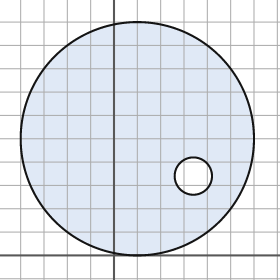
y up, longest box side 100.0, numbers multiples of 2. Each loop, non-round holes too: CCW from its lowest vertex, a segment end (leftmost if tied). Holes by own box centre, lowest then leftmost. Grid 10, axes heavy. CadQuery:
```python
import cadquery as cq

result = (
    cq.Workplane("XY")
    .moveTo(10.0, 50.0)
    .circle(50.0)
    .moveTo(34.0, 34.0)
    .circle(8.0)
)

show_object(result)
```